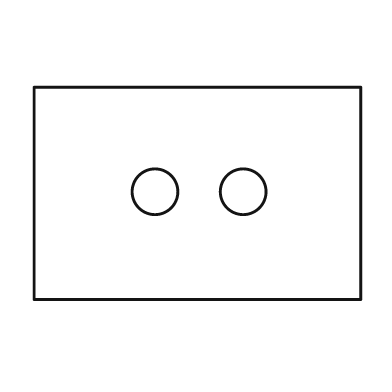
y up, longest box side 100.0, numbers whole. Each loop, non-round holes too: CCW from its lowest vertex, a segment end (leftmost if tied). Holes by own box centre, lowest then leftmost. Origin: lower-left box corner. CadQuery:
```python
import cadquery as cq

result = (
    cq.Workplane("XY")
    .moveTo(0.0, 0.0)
    .lineTo(100.0, 0.0)
    .lineTo(100.0, 65.0)
    .lineTo(0.0, 65.0)
    .close()
    .moveTo(37.0, 33.0)
    .circle(7.0)
    .moveTo(64.0, 33.0)
    .circle(7.0)
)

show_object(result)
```